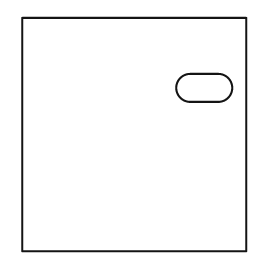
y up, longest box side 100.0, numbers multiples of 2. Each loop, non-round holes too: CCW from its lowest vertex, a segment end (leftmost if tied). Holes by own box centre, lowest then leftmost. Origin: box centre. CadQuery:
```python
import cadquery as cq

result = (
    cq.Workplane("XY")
    .moveTo(-48.0, -50.0)
    .lineTo(48.0, -50.0)
    .lineTo(48.0, 50.0)
    .lineTo(-48.0, 50.0)
    .close()
    .moveTo(24.0, 14.0)
    .lineTo(36.0, 14.0)
    .threePointArc((42.0, 20.0), (36.0, 26.0))
    .lineTo(24.0, 26.0)
    .threePointArc((18.0, 20.0), (24.0, 14.0))
    .close()
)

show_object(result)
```